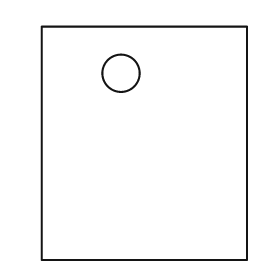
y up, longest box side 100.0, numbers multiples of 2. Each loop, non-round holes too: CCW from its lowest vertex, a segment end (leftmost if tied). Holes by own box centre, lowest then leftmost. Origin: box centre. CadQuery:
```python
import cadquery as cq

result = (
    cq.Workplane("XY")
    .moveTo(-44.0, -50.0)
    .lineTo(44.0, -50.0)
    .lineTo(44.0, 50.0)
    .lineTo(-44.0, 50.0)
    .close()
    .moveTo(-10.0, 30.0)
    .circle(8.0)
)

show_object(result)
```